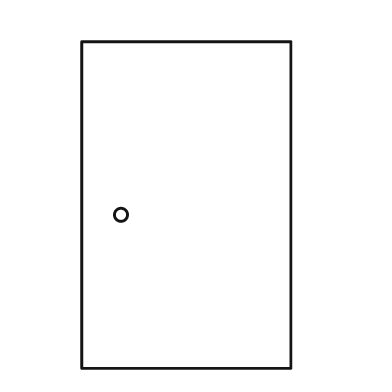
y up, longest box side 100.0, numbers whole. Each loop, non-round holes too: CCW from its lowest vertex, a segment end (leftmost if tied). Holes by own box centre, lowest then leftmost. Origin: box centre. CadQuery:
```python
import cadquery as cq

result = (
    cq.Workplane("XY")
    .moveTo(-32.0, -50.0)
    .lineTo(32.0, -50.0)
    .lineTo(32.0, 50.0)
    .lineTo(-32.0, 50.0)
    .close()
    .moveTo(-20.0, -3.0)
    .circle(2.0)
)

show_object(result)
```